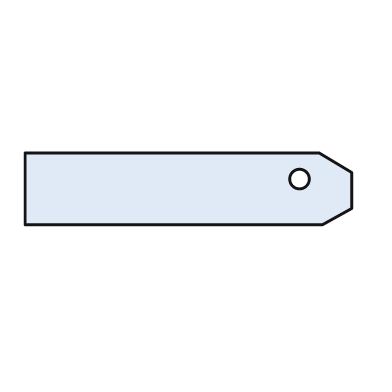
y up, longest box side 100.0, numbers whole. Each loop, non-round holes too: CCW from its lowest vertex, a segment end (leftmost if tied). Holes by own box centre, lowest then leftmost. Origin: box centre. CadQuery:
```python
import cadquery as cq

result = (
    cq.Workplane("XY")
    .moveTo(-50.0, -11.0)
    .lineTo(41.0, -11.0)
    .lineTo(50.0, -6.0)
    .lineTo(50.0, 5.0)
    .lineTo(40.0, 11.0)
    .lineTo(-50.0, 11.0)
    .close()
    .moveTo(34.0, 3.0)
    .circle(3.0)
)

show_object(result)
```